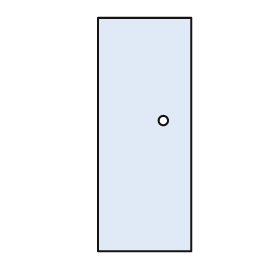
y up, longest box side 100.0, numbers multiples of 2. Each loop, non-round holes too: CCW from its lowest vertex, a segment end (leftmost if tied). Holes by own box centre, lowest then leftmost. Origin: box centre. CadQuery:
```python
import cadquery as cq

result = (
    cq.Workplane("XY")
    .moveTo(-20.0, -50.0)
    .lineTo(20.0, -50.0)
    .lineTo(20.0, 50.0)
    .lineTo(-20.0, 50.0)
    .close()
    .moveTo(8.0, 6.0)
    .circle(2.0)
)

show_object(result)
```